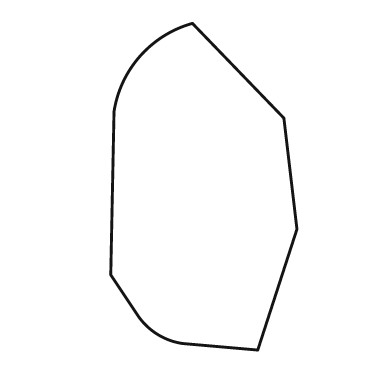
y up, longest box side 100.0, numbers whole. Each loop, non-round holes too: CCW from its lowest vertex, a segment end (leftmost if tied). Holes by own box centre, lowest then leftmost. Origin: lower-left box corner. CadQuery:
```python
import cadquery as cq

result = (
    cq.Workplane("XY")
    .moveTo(45.0, 0.0)
    .lineTo(57.0, 37.0)
    .lineTo(53.0, 71.0)
    .lineTo(25.0, 100.0)
    .threePointArc((9.0, 90.0), (1.0, 73.0))
    .lineTo(0.0, 23.0)
    .lineTo(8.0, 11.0)
    .threePointArc((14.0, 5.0), (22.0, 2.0))
    .close()
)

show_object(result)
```